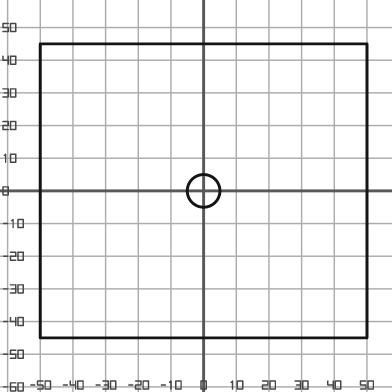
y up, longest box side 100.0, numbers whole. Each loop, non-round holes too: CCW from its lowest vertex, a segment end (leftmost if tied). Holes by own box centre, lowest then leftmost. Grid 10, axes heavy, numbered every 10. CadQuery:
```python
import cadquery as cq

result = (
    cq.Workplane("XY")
    .moveTo(-50.0, -45.0)
    .lineTo(50.0, -45.0)
    .lineTo(50.0, 45.0)
    .lineTo(-50.0, 45.0)
    .close()
    .moveTo(0.0, 0.0)
    .circle(5.0)
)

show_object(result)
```